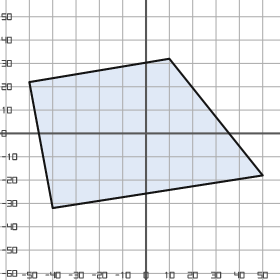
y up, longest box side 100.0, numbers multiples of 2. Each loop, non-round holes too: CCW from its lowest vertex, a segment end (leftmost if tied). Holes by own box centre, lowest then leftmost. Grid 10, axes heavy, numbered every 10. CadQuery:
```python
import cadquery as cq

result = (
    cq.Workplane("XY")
    .moveTo(-40.0, -32.0)
    .lineTo(50.0, -18.0)
    .lineTo(10.0, 32.0)
    .lineTo(-50.0, 22.0)
    .close()
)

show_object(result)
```